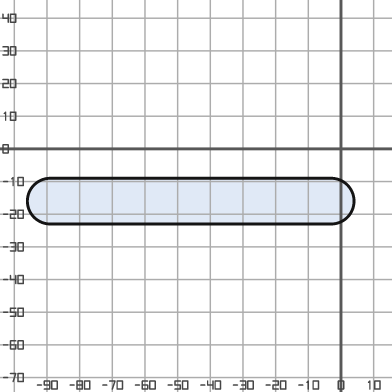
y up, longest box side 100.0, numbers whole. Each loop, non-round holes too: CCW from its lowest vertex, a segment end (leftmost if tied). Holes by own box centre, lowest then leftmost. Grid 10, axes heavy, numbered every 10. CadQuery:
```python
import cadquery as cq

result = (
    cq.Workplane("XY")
    .moveTo(-89.0, -23.0)
    .lineTo(-3.0, -23.0)
    .threePointArc((4.0, -16.0), (-3.0, -9.0))
    .lineTo(-89.0, -9.0)
    .threePointArc((-96.0, -16.0), (-89.0, -23.0))
    .close()
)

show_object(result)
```